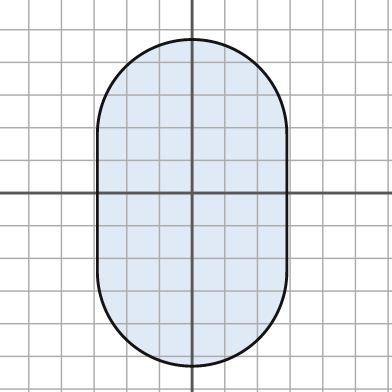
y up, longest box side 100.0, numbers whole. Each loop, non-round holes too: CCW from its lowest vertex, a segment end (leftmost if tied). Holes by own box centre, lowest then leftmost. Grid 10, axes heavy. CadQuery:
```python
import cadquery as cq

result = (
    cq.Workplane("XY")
    .moveTo(-29.0, -24.0)
    .threePointArc((0.0, -53.0), (29.0, -24.0))
    .lineTo(29.0, 18.0)
    .threePointArc((0.0, 47.0), (-29.0, 18.0))
    .close()
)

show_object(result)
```